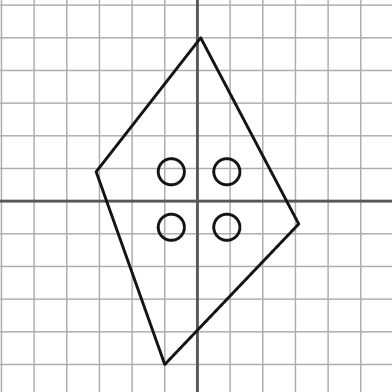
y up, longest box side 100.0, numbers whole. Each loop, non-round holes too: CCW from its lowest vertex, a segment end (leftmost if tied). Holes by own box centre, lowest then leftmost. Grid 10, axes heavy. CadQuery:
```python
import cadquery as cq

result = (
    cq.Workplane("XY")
    .moveTo(-10.0, -50.0)
    .lineTo(31.0, -7.0)
    .lineTo(1.0, 50.0)
    .lineTo(-31.0, 9.0)
    .close()
    .moveTo(-8.0, -8.0)
    .circle(4.0)
    .moveTo(9.0, -8.0)
    .circle(4.0)
    .moveTo(-8.0, 9.0)
    .circle(4.0)
    .moveTo(9.0, 9.0)
    .circle(4.0)
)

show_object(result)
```